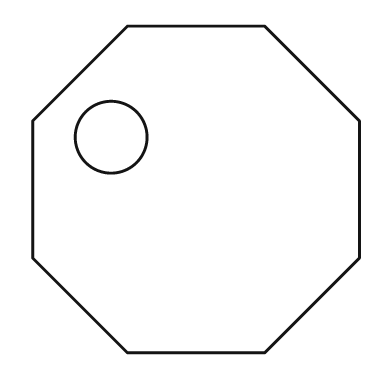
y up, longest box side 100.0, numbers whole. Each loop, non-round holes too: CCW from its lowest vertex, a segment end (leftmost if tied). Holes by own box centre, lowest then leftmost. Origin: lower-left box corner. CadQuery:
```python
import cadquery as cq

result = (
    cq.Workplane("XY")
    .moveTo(29.0, 0.0)
    .lineTo(71.0, 0.0)
    .lineTo(100.0, 29.0)
    .lineTo(100.0, 71.0)
    .lineTo(71.0, 100.0)
    .lineTo(29.0, 100.0)
    .lineTo(0.0, 71.0)
    .lineTo(0.0, 29.0)
    .close()
    .moveTo(24.0, 66.0)
    .circle(11.0)
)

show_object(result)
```